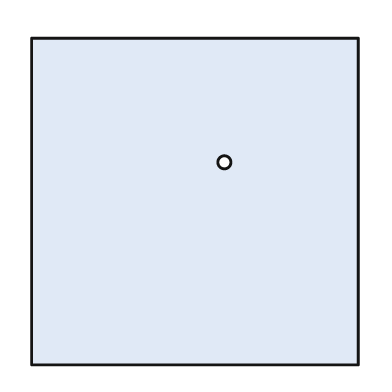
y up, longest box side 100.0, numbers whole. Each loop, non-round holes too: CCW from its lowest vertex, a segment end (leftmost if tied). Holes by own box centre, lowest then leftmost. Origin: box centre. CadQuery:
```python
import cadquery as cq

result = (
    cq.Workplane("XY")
    .moveTo(-50.0, -50.0)
    .lineTo(50.0, -50.0)
    .lineTo(50.0, 50.0)
    .lineTo(-50.0, 50.0)
    .close()
    .moveTo(9.0, 12.0)
    .circle(2.0)
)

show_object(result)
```